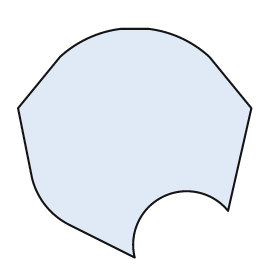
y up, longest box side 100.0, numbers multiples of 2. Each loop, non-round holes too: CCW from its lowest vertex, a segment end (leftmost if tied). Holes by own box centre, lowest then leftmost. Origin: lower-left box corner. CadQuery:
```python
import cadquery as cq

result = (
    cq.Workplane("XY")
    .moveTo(50.0, 0.0)
    .threePointArc((62.0, 26.0), (90.0, 20.0))
    .lineTo(100.0, 64.0)
    .lineTo(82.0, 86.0)
    .threePointArc((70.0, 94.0), (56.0, 98.0))
    .lineTo(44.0, 98.0)
    .threePointArc((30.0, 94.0), (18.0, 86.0))
    .lineTo(0.0, 64.0)
    .lineTo(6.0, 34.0)
    .threePointArc((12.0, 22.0), (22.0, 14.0))
    .close()
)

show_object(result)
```